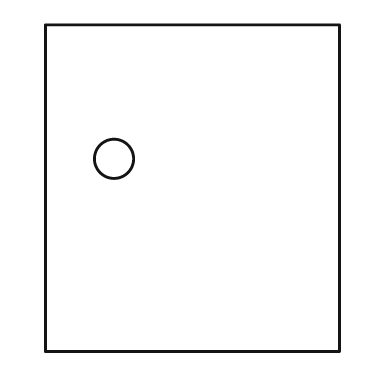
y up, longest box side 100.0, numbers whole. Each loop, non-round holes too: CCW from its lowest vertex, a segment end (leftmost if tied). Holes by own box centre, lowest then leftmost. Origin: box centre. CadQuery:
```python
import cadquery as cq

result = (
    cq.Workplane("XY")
    .moveTo(-45.0, -50.0)
    .lineTo(45.0, -50.0)
    .lineTo(45.0, 50.0)
    .lineTo(-45.0, 50.0)
    .close()
    .moveTo(-24.0, 9.0)
    .circle(6.0)
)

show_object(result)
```